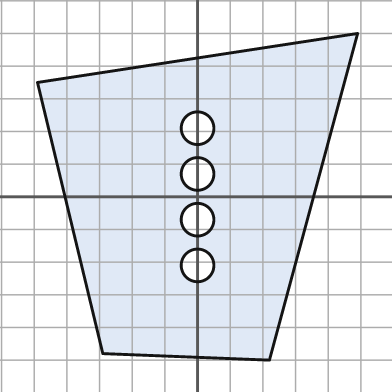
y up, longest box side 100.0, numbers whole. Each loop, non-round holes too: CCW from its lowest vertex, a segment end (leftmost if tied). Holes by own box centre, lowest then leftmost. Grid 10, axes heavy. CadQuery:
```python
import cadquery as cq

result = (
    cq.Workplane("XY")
    .moveTo(22.0, -50.0)
    .lineTo(49.0, 50.0)
    .lineTo(-49.0, 35.0)
    .lineTo(-29.0, -48.0)
    .close()
    .moveTo(0.0, -21.0)
    .circle(5.0)
    .moveTo(0.0, -7.0)
    .circle(5.0)
    .moveTo(0.0, 7.0)
    .circle(5.0)
    .moveTo(0.0, 21.0)
    .circle(5.0)
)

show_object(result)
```